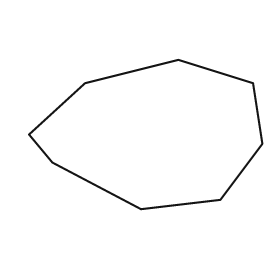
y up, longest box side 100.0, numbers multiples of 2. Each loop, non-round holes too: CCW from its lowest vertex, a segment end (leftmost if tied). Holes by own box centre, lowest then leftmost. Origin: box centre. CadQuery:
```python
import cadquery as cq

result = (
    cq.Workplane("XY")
    .moveTo(-2.0, -32.0)
    .lineTo(32.0, -28.0)
    .lineTo(50.0, -4.0)
    .lineTo(46.0, 22.0)
    .lineTo(14.0, 32.0)
    .lineTo(-26.0, 22.0)
    .lineTo(-50.0, 0.0)
    .lineTo(-40.0, -12.0)
    .close()
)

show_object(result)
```